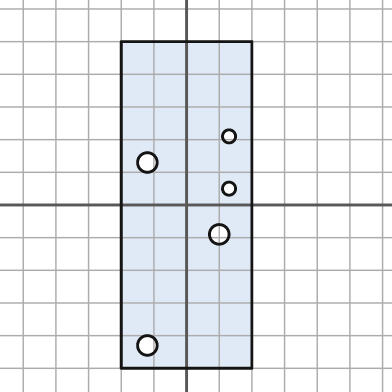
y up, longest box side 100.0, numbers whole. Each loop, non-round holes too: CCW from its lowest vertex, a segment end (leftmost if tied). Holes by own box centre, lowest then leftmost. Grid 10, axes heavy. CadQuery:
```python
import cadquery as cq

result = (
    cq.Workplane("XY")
    .moveTo(-20.0, -50.0)
    .lineTo(20.0, -50.0)
    .lineTo(20.0, 50.0)
    .lineTo(-20.0, 50.0)
    .close()
    .moveTo(-12.0, -43.0)
    .circle(3.0)
    .moveTo(10.0, -9.0)
    .circle(3.0)
    .moveTo(13.0, 5.0)
    .circle(2.0)
    .moveTo(-12.0, 13.0)
    .circle(3.0)
    .moveTo(13.0, 21.0)
    .circle(2.0)
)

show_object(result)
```